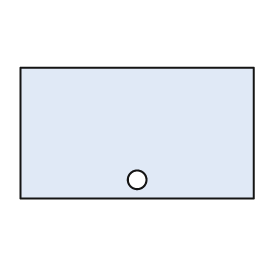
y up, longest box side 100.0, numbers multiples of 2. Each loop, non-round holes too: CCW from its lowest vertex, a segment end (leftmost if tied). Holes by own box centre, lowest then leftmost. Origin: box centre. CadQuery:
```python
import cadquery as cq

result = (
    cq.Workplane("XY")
    .moveTo(-50.0, -28.0)
    .lineTo(50.0, -28.0)
    .lineTo(50.0, 28.0)
    .lineTo(-50.0, 28.0)
    .close()
    .moveTo(0.0, -20.0)
    .circle(4.0)
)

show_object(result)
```